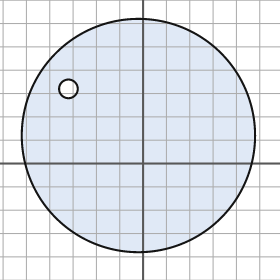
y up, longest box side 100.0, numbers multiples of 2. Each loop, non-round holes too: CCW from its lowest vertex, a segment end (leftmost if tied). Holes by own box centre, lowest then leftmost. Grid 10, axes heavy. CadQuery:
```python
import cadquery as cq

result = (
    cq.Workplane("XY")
    .moveTo(-2.0, 12.0)
    .circle(50.0)
    .moveTo(-32.0, 32.0)
    .circle(4.0)
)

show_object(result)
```